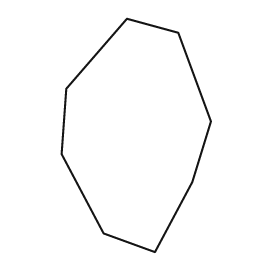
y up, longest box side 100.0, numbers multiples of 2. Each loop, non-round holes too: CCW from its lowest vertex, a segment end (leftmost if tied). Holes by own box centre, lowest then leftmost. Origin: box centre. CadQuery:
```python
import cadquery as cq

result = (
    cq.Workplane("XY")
    .moveTo(8.0, -50.0)
    .lineTo(24.0, -20.0)
    .lineTo(32.0, 6.0)
    .lineTo(18.0, 44.0)
    .lineTo(-4.0, 50.0)
    .lineTo(-30.0, 20.0)
    .lineTo(-32.0, -8.0)
    .lineTo(-14.0, -42.0)
    .close()
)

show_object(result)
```